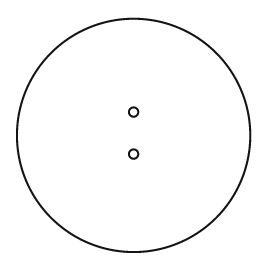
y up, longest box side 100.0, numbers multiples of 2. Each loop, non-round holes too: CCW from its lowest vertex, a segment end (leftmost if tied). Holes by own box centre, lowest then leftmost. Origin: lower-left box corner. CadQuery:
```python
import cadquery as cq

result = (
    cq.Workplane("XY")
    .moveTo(50.0, 50.0)
    .circle(50.0)
    .moveTo(50.0, 42.0)
    .circle(2.0)
    .moveTo(50.0, 60.0)
    .circle(2.0)
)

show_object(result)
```